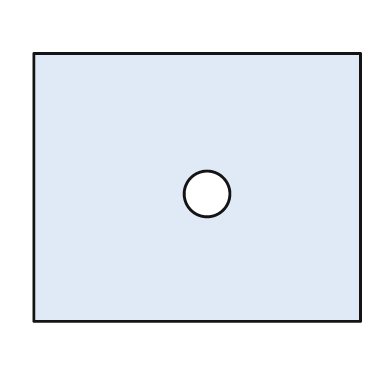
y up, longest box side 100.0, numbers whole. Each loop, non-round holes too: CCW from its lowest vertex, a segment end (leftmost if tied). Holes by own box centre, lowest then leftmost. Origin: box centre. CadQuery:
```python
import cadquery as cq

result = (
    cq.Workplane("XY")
    .moveTo(-50.0, -41.0)
    .lineTo(50.0, -41.0)
    .lineTo(50.0, 41.0)
    .lineTo(-50.0, 41.0)
    .close()
    .moveTo(3.0, -2.0)
    .circle(7.0)
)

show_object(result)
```